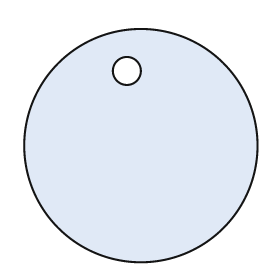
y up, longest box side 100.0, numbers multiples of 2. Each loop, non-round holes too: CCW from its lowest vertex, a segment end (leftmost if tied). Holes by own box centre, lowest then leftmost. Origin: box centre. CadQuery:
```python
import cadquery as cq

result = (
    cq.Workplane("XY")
    .moveTo(0.0, 0.0)
    .circle(50.0)
    .moveTo(-6.0, 32.0)
    .circle(6.0)
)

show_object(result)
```